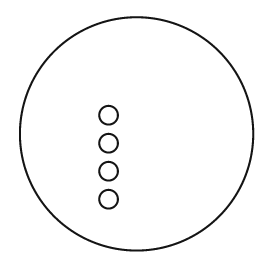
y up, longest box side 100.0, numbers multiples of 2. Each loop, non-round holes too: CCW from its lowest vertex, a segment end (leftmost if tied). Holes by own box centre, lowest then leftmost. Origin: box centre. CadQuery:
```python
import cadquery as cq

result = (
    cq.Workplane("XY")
    .moveTo(0.0, 0.0)
    .circle(50.0)
    .moveTo(-12.0, -28.0)
    .circle(4.0)
    .moveTo(-12.0, -16.0)
    .circle(4.0)
    .moveTo(-12.0, -4.0)
    .circle(4.0)
    .moveTo(-12.0, 8.0)
    .circle(4.0)
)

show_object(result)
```